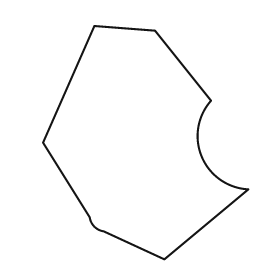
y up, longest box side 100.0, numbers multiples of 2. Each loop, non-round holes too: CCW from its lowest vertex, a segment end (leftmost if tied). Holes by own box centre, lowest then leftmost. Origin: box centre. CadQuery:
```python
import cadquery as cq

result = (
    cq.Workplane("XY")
    .moveTo(8.0, -50.0)
    .lineTo(44.0, -20.0)
    .threePointArc((24.0, -6.0), (28.0, 18.0))
    .lineTo(4.0, 48.0)
    .lineTo(-22.0, 50.0)
    .lineTo(-44.0, 0.0)
    .lineTo(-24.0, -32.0)
    .threePointArc((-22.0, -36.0), (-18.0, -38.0))
    .close()
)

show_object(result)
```